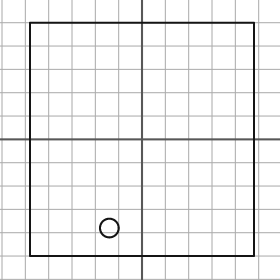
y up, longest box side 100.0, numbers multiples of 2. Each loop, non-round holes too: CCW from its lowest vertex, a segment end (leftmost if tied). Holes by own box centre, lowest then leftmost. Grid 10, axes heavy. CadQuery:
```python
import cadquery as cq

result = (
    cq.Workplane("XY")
    .moveTo(-48.0, -50.0)
    .lineTo(48.0, -50.0)
    .lineTo(48.0, 50.0)
    .lineTo(-48.0, 50.0)
    .close()
    .moveTo(-14.0, -38.0)
    .circle(4.0)
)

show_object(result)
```